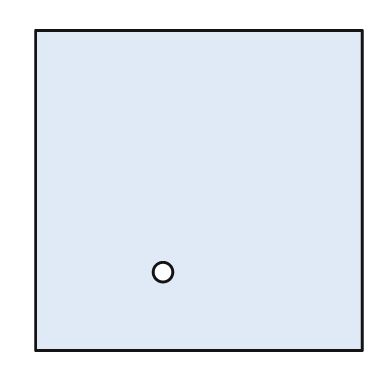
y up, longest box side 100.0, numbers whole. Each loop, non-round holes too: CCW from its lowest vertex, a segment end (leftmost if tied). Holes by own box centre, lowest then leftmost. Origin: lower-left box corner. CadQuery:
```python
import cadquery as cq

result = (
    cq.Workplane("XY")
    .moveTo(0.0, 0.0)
    .lineTo(100.0, 0.0)
    .lineTo(100.0, 98.0)
    .lineTo(0.0, 98.0)
    .close()
    .moveTo(39.0, 24.0)
    .circle(3.0)
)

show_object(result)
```